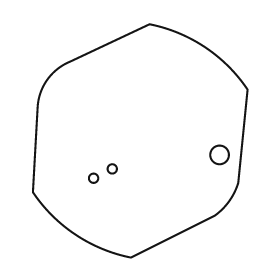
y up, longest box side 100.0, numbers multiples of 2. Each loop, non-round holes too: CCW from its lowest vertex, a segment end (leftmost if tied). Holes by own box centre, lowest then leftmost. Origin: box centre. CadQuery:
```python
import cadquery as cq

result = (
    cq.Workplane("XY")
    .moveTo(-4.0, -50.0)
    .lineTo(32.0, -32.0)
    .threePointArc((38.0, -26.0), (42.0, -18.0))
    .lineTo(46.0, 22.0)
    .threePointArc((28.0, 40.0), (4.0, 50.0))
    .lineTo(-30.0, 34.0)
    .threePointArc((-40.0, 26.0), (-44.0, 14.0))
    .lineTo(-46.0, -22.0)
    .threePointArc((-28.0, -40.0), (-4.0, -50.0))
    .close()
    .moveTo(-20.0, -16.0)
    .circle(2.0)
    .moveTo(-12.0, -12.0)
    .circle(2.0)
    .moveTo(34.0, -6.0)
    .circle(4.0)
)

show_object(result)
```